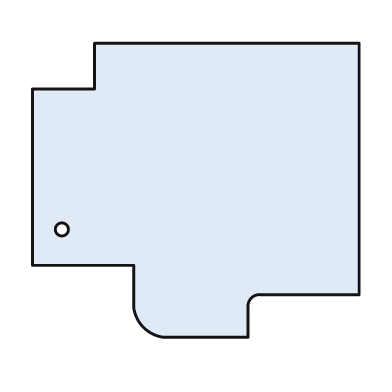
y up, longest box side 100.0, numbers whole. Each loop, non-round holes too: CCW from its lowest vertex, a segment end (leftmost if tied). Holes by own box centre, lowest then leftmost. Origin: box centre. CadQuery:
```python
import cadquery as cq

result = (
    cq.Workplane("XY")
    .moveTo(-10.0, -45.0)
    .lineTo(16.0, -45.0)
    .lineTo(16.0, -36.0)
    .threePointArc((17.0, -33.0), (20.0, -32.0))
    .lineTo(50.0, -32.0)
    .lineTo(50.0, 45.0)
    .lineTo(-31.0, 45.0)
    .lineTo(-31.0, 31.0)
    .lineTo(-50.0, 31.0)
    .lineTo(-50.0, -23.0)
    .lineTo(-19.0, -23.0)
    .lineTo(-19.0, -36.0)
    .threePointArc((-16.0, -42.0), (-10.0, -45.0))
    .close()
    .moveTo(-41.0, -12.0)
    .circle(2.0)
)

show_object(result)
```